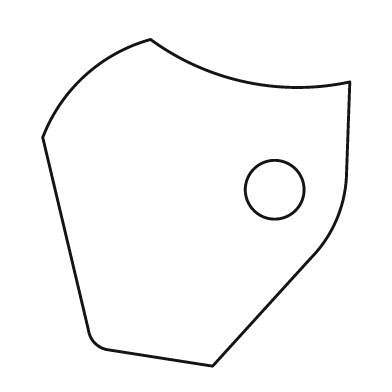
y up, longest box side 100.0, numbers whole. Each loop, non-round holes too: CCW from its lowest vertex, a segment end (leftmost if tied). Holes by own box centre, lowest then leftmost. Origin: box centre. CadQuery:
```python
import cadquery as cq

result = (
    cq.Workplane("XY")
    .moveTo(5.0, -50.0)
    .lineTo(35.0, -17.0)
    .threePointArc((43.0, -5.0), (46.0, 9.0))
    .lineTo(47.0, 37.0)
    .threePointArc((15.0, 37.0), (-14.0, 50.0))
    .threePointArc((-34.0, 39.0), (-47.0, 20.0))
    .lineTo(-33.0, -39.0)
    .threePointArc((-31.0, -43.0), (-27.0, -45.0))
    .close()
    .moveTo(24.0, 4.0)
    .circle(9.0)
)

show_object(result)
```